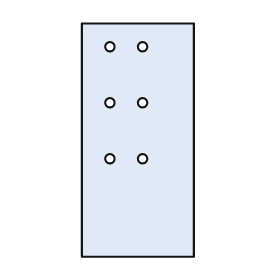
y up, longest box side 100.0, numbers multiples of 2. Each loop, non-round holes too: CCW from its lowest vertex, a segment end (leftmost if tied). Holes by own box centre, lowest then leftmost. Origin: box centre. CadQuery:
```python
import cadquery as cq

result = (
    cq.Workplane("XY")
    .moveTo(-24.0, -50.0)
    .lineTo(24.0, -50.0)
    .lineTo(24.0, 50.0)
    .lineTo(-24.0, 50.0)
    .close()
    .moveTo(-12.0, -8.0)
    .circle(2.0)
    .moveTo(2.0, -8.0)
    .circle(2.0)
    .moveTo(-12.0, 16.0)
    .circle(2.0)
    .moveTo(2.0, 16.0)
    .circle(2.0)
    .moveTo(-12.0, 40.0)
    .circle(2.0)
    .moveTo(2.0, 40.0)
    .circle(2.0)
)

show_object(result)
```